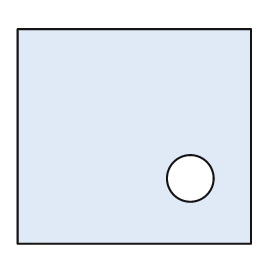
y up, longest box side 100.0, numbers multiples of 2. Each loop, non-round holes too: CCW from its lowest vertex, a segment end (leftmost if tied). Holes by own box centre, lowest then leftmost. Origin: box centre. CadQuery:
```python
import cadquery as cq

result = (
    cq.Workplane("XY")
    .moveTo(-50.0, -46.0)
    .lineTo(50.0, -46.0)
    .lineTo(50.0, 46.0)
    .lineTo(-50.0, 46.0)
    .close()
    .moveTo(24.0, -18.0)
    .circle(10.0)
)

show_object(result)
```